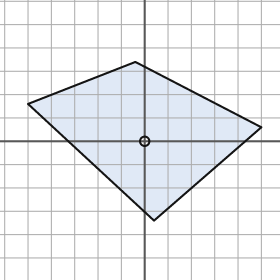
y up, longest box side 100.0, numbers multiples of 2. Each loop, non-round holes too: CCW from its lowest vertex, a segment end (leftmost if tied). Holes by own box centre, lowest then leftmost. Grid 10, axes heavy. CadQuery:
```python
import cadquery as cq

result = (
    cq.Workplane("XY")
    .moveTo(4.0, -34.0)
    .lineTo(50.0, 6.0)
    .lineTo(-4.0, 34.0)
    .lineTo(-50.0, 16.0)
    .close()
    .moveTo(0.0, 0.0)
    .circle(2.0)
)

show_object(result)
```